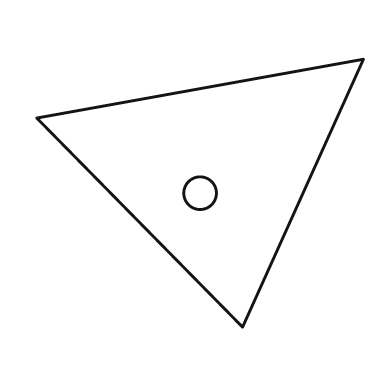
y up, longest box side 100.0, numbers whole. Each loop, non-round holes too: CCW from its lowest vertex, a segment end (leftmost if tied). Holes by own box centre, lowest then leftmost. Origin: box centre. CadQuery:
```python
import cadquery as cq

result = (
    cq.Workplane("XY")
    .moveTo(13.0, -41.0)
    .lineTo(50.0, 41.0)
    .lineTo(-50.0, 23.0)
    .close()
    .moveTo(0.0, 0.0)
    .circle(5.0)
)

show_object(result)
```